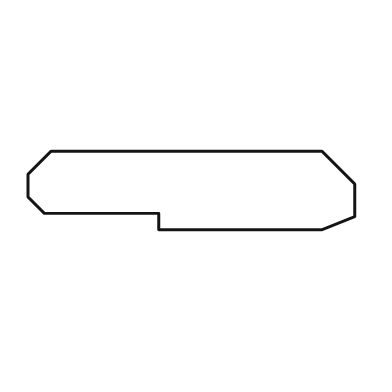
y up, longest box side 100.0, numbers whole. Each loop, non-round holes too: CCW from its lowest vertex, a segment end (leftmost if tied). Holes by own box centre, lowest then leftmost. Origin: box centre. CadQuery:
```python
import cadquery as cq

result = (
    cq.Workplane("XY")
    .moveTo(-10.0, -12.0)
    .lineTo(40.0, -12.0)
    .lineTo(50.0, -8.0)
    .lineTo(50.0, 2.0)
    .lineTo(40.0, 12.0)
    .lineTo(-43.0, 12.0)
    .lineTo(-50.0, 5.0)
    .lineTo(-50.0, -2.0)
    .lineTo(-45.0, -7.0)
    .lineTo(-10.0, -7.0)
    .close()
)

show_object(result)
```